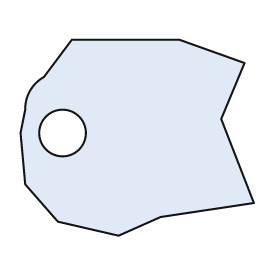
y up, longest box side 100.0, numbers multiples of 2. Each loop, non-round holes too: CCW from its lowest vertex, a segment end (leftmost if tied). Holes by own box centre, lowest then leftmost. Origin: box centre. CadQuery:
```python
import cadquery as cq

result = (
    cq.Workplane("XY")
    .moveTo(-8.0, -42.0)
    .lineTo(10.0, -34.0)
    .lineTo(50.0, -28.0)
    .lineTo(36.0, 8.0)
    .lineTo(46.0, 32.0)
    .lineTo(18.0, 42.0)
    .lineTo(-28.0, 42.0)
    .lineTo(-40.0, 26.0)
    .threePointArc((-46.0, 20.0), (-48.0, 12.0))
    .lineTo(-50.0, 2.0)
    .lineTo(-48.0, -20.0)
    .lineTo(-34.0, -36.0)
    .close()
    .moveTo(-32.0, 2.0)
    .circle(10.0)
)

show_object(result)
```